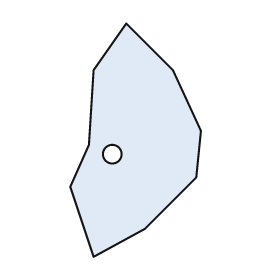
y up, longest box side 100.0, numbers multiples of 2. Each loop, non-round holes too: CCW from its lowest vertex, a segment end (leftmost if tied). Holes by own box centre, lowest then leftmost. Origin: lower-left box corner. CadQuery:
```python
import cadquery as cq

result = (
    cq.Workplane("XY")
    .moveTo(10.0, 0.0)
    .lineTo(32.0, 12.0)
    .lineTo(54.0, 34.0)
    .lineTo(56.0, 54.0)
    .lineTo(44.0, 80.0)
    .lineTo(24.0, 100.0)
    .lineTo(10.0, 80.0)
    .lineTo(8.0, 48.0)
    .lineTo(0.0, 30.0)
    .close()
    .moveTo(18.0, 44.0)
    .circle(4.0)
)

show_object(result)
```